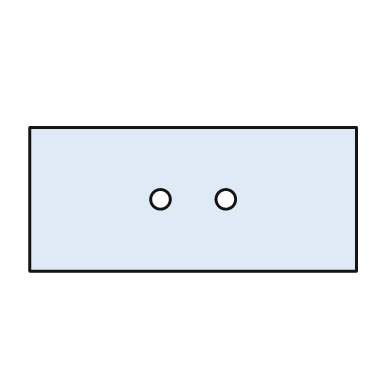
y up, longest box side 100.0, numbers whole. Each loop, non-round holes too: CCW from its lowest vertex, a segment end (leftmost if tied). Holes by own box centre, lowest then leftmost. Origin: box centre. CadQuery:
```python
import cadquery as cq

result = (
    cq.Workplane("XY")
    .moveTo(-50.0, -22.0)
    .lineTo(50.0, -22.0)
    .lineTo(50.0, 22.0)
    .lineTo(-50.0, 22.0)
    .close()
    .moveTo(-10.0, 0.0)
    .circle(3.0)
    .moveTo(10.0, 0.0)
    .circle(3.0)
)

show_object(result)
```